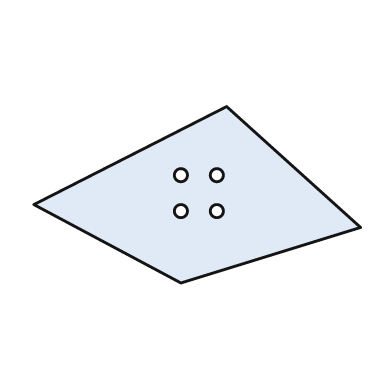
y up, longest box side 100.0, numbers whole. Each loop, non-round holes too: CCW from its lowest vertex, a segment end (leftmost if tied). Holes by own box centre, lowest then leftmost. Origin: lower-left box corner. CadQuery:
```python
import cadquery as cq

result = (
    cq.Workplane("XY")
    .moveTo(45.0, 0.0)
    .lineTo(100.0, 17.0)
    .lineTo(59.0, 54.0)
    .lineTo(0.0, 24.0)
    .close()
    .moveTo(45.0, 22.0)
    .circle(2.0)
    .moveTo(56.0, 22.0)
    .circle(2.0)
    .moveTo(45.0, 33.0)
    .circle(2.0)
    .moveTo(56.0, 33.0)
    .circle(2.0)
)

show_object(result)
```